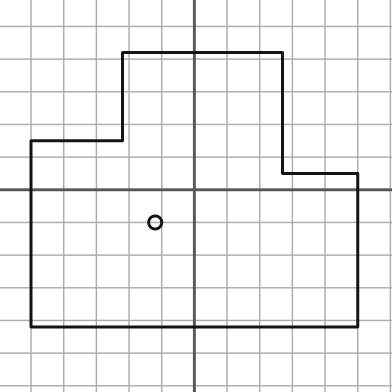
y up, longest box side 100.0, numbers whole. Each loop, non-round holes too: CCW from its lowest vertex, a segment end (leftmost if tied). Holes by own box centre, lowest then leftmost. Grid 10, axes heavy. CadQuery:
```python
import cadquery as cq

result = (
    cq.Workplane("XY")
    .moveTo(-50.0, -42.0)
    .lineTo(50.0, -42.0)
    .lineTo(50.0, 5.0)
    .lineTo(27.0, 5.0)
    .lineTo(27.0, 42.0)
    .lineTo(-22.0, 42.0)
    .lineTo(-22.0, 15.0)
    .lineTo(-50.0, 15.0)
    .close()
    .moveTo(-12.0, -10.0)
    .circle(2.0)
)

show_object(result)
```